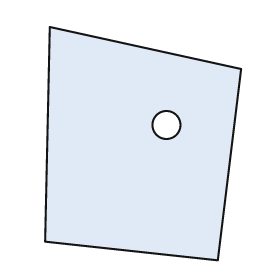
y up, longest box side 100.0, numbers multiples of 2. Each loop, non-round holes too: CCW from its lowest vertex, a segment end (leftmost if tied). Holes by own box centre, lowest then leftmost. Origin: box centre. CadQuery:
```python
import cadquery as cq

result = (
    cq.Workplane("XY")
    .moveTo(32.0, -50.0)
    .lineTo(42.0, 32.0)
    .lineTo(-40.0, 50.0)
    .lineTo(-42.0, -42.0)
    .close()
    .moveTo(10.0, 8.0)
    .circle(6.0)
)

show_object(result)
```